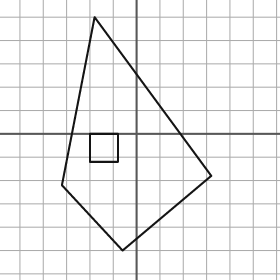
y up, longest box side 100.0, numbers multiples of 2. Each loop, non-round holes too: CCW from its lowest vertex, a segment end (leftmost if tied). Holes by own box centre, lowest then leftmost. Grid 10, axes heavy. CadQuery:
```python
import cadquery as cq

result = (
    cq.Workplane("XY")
    .moveTo(-6.0, -50.0)
    .lineTo(32.0, -18.0)
    .lineTo(-18.0, 50.0)
    .lineTo(-32.0, -22.0)
    .close()
    .moveTo(-20.0, -12.0)
    .lineTo(-8.0, -12.0)
    .lineTo(-8.0, 0.0)
    .lineTo(-20.0, 0.0)
    .close()
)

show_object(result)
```